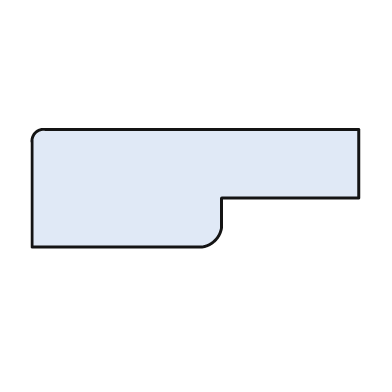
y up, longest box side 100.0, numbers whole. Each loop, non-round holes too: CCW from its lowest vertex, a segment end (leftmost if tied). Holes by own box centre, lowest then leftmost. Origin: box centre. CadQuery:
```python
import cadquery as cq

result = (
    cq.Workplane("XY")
    .moveTo(-50.0, -18.0)
    .lineTo(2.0, -18.0)
    .threePointArc((6.0, -16.0), (8.0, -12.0))
    .lineTo(8.0, -3.0)
    .lineTo(50.0, -3.0)
    .lineTo(50.0, 18.0)
    .lineTo(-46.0, 18.0)
    .threePointArc((-49.0, 17.0), (-50.0, 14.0))
    .close()
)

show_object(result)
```